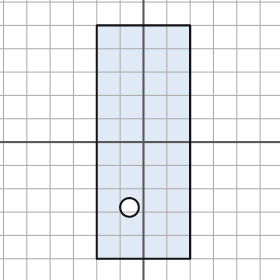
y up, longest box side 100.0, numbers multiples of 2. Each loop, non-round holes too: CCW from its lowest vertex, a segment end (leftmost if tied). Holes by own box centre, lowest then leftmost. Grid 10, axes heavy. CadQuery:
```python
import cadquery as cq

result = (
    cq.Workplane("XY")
    .moveTo(-20.0, -50.0)
    .lineTo(20.0, -50.0)
    .lineTo(20.0, 50.0)
    .lineTo(-20.0, 50.0)
    .close()
    .moveTo(-6.0, -28.0)
    .circle(4.0)
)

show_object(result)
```